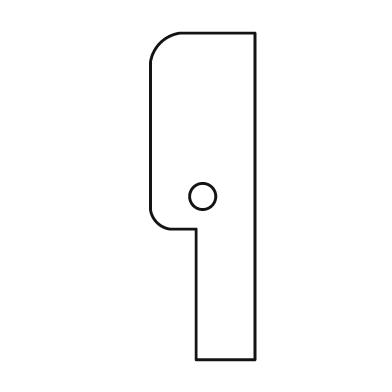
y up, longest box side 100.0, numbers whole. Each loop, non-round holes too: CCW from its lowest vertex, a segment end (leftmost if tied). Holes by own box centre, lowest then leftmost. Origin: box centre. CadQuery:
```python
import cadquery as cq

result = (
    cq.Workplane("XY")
    .moveTo(-2.0, -50.0)
    .lineTo(16.0, -50.0)
    .lineTo(16.0, 50.0)
    .lineTo(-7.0, 50.0)
    .threePointArc((-13.0, 47.0), (-16.0, 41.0))
    .lineTo(-16.0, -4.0)
    .threePointArc((-14.0, -8.0), (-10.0, -10.0))
    .lineTo(-2.0, -10.0)
    .close()
    .moveTo(0.0, 0.0)
    .circle(4.0)
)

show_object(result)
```